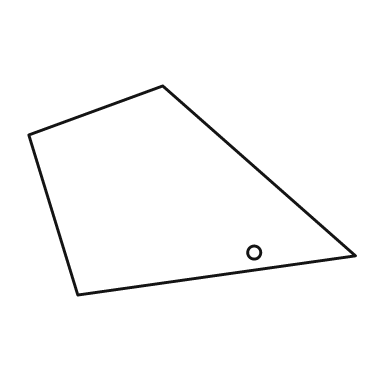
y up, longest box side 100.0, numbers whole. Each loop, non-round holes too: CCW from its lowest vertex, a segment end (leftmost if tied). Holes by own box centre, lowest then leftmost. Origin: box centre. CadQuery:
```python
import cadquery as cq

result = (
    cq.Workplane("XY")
    .moveTo(-35.0, -32.0)
    .lineTo(50.0, -20.0)
    .lineTo(-9.0, 32.0)
    .lineTo(-50.0, 17.0)
    .close()
    .moveTo(19.0, -19.0)
    .circle(2.0)
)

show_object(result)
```